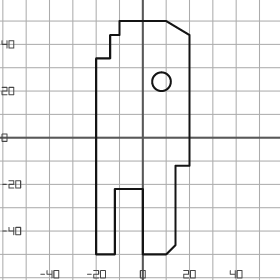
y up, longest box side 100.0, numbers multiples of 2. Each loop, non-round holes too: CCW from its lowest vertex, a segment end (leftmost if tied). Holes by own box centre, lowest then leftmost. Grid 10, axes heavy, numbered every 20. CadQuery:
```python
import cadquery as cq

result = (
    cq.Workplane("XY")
    .moveTo(-20.0, -50.0)
    .lineTo(-12.0, -50.0)
    .lineTo(-12.0, -22.0)
    .lineTo(0.0, -22.0)
    .lineTo(0.0, -50.0)
    .lineTo(10.0, -50.0)
    .lineTo(14.0, -46.0)
    .lineTo(14.0, -12.0)
    .lineTo(20.0, -12.0)
    .lineTo(20.0, 44.0)
    .lineTo(10.0, 50.0)
    .lineTo(-10.0, 50.0)
    .lineTo(-10.0, 44.0)
    .lineTo(-14.0, 44.0)
    .lineTo(-14.0, 34.0)
    .lineTo(-20.0, 34.0)
    .close()
    .moveTo(8.0, 24.0)
    .circle(4.0)
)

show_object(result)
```